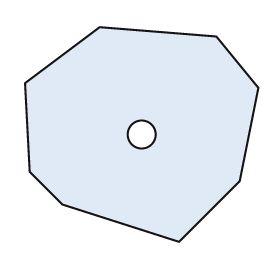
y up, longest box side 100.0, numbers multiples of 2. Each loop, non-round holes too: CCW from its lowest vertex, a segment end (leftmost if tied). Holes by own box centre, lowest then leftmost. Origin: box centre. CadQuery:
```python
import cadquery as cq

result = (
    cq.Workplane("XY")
    .moveTo(16.0, -46.0)
    .lineTo(42.0, -20.0)
    .lineTo(50.0, 20.0)
    .lineTo(32.0, 42.0)
    .lineTo(-18.0, 46.0)
    .lineTo(-50.0, 22.0)
    .lineTo(-48.0, -16.0)
    .lineTo(-34.0, -30.0)
    .close()
    .moveTo(0.0, 0.0)
    .circle(6.0)
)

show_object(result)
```